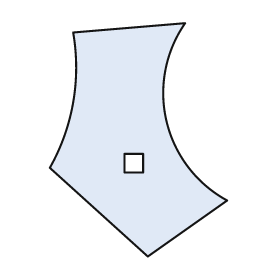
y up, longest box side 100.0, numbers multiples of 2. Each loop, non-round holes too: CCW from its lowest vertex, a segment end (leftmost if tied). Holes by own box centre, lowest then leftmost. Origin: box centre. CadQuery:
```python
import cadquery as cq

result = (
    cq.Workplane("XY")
    .moveTo(4.0, -50.0)
    .lineTo(38.0, -26.0)
    .threePointArc((12.0, 8.0), (20.0, 50.0))
    .lineTo(-28.0, 46.0)
    .threePointArc((-28.0, 16.0), (-38.0, -12.0))
    .close()
    .moveTo(-6.0, -14.0)
    .lineTo(2.0, -14.0)
    .lineTo(2.0, -6.0)
    .lineTo(-6.0, -6.0)
    .close()
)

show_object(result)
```